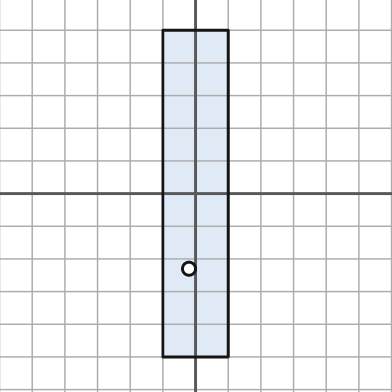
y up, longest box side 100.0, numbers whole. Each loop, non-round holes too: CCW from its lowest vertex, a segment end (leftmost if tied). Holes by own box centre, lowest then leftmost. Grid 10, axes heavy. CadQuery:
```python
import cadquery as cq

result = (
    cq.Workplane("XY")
    .moveTo(-10.0, -50.0)
    .lineTo(10.0, -50.0)
    .lineTo(10.0, 50.0)
    .lineTo(-10.0, 50.0)
    .close()
    .moveTo(-2.0, -23.0)
    .circle(2.0)
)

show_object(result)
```